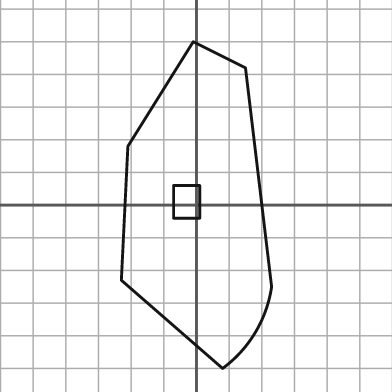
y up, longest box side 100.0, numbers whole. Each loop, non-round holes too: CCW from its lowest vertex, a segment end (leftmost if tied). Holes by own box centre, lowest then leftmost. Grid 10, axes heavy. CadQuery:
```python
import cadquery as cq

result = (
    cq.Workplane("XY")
    .moveTo(8.0, -50.0)
    .threePointArc((18.0, -39.0), (23.0, -25.0))
    .lineTo(15.0, 42.0)
    .lineTo(-1.0, 50.0)
    .lineTo(-21.0, 18.0)
    .lineTo(-23.0, -23.0)
    .close()
    .moveTo(-7.0, -4.0)
    .lineTo(1.0, -4.0)
    .lineTo(1.0, 6.0)
    .lineTo(-7.0, 6.0)
    .close()
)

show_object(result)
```